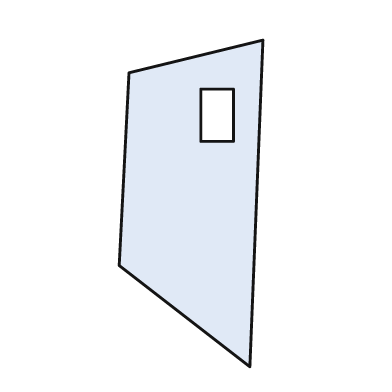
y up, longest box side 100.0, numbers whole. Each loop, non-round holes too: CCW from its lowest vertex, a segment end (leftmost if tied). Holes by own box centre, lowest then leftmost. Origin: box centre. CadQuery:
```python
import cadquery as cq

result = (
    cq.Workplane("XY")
    .moveTo(18.0, -50.0)
    .lineTo(22.0, 50.0)
    .lineTo(-19.0, 40.0)
    .lineTo(-22.0, -19.0)
    .close()
    .moveTo(3.0, 19.0)
    .lineTo(13.0, 19.0)
    .lineTo(13.0, 35.0)
    .lineTo(3.0, 35.0)
    .close()
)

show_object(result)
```